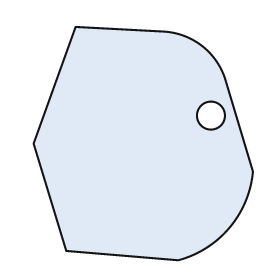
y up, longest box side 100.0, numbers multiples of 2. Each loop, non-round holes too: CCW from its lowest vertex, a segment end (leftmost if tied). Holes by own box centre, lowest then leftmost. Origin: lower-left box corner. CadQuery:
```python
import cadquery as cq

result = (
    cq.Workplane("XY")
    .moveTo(62.0, 0.0)
    .threePointArc((84.0, 14.0), (94.0, 38.0))
    .lineTo(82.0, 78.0)
    .threePointArc((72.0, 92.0), (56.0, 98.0))
    .lineTo(18.0, 100.0)
    .lineTo(0.0, 50.0)
    .lineTo(14.0, 4.0)
    .close()
    .moveTo(76.0, 62.0)
    .circle(6.0)
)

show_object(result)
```